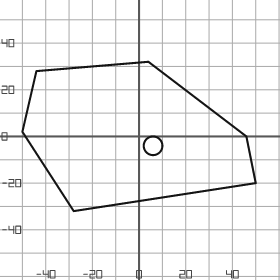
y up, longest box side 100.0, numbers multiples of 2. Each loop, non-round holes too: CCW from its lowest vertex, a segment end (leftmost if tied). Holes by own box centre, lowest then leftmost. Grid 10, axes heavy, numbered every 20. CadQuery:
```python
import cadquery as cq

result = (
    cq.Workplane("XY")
    .moveTo(-28.0, -32.0)
    .lineTo(50.0, -20.0)
    .lineTo(46.0, 0.0)
    .lineTo(4.0, 32.0)
    .lineTo(-44.0, 28.0)
    .lineTo(-50.0, 2.0)
    .close()
    .moveTo(6.0, -4.0)
    .circle(4.0)
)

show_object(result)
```